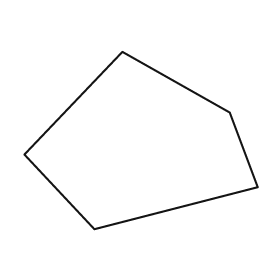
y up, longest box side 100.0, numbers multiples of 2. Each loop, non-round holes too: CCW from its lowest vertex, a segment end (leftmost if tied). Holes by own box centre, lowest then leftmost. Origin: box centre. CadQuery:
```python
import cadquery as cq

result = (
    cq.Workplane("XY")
    .moveTo(-20.0, -38.0)
    .lineTo(50.0, -20.0)
    .lineTo(38.0, 12.0)
    .lineTo(-8.0, 38.0)
    .lineTo(-50.0, -6.0)
    .close()
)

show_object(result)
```